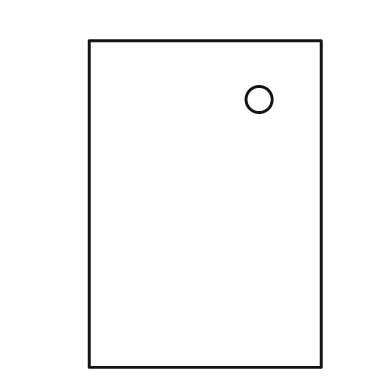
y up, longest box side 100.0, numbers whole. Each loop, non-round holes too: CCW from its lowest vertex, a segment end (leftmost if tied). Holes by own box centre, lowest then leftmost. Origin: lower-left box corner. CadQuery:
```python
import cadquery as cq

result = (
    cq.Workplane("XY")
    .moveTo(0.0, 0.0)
    .lineTo(71.0, 0.0)
    .lineTo(71.0, 100.0)
    .lineTo(0.0, 100.0)
    .close()
    .moveTo(52.0, 82.0)
    .circle(4.0)
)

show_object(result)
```